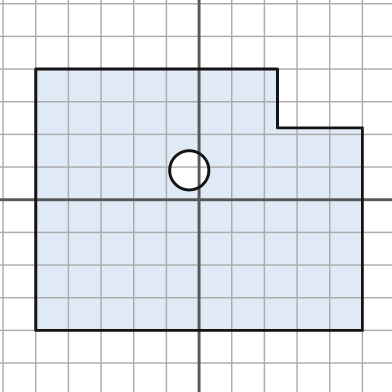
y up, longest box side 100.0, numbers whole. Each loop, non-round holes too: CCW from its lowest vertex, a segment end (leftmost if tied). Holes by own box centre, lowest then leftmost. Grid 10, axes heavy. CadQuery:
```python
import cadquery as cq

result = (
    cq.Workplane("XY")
    .moveTo(-50.0, -40.0)
    .lineTo(50.0, -40.0)
    .lineTo(50.0, 22.0)
    .lineTo(24.0, 22.0)
    .lineTo(24.0, 40.0)
    .lineTo(-50.0, 40.0)
    .close()
    .moveTo(-3.0, 9.0)
    .circle(6.0)
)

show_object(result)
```